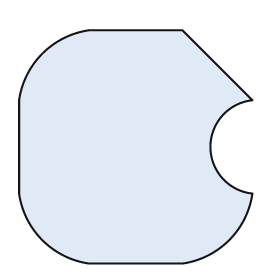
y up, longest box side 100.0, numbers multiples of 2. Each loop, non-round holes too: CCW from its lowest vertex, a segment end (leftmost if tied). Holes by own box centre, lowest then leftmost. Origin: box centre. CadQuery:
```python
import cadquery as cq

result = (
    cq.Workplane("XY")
    .moveTo(-20.0, -50.0)
    .lineTo(20.0, -50.0)
    .threePointArc((40.0, -40.0), (50.0, -20.0))
    .threePointArc((32.0, 0.0), (50.0, 20.0))
    .lineTo(20.0, 50.0)
    .lineTo(-20.0, 50.0)
    .threePointArc((-40.0, 40.0), (-50.0, 20.0))
    .lineTo(-50.0, -20.0)
    .threePointArc((-40.0, -40.0), (-20.0, -50.0))
    .close()
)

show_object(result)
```